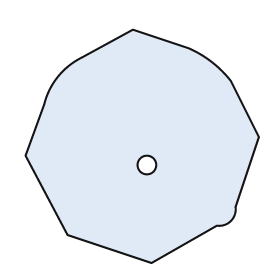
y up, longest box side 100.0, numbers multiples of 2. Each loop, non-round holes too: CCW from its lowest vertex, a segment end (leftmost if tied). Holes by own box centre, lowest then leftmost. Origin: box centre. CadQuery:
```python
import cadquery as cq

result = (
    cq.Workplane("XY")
    .moveTo(4.0, -50.0)
    .lineTo(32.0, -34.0)
    .threePointArc((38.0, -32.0), (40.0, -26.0))
    .lineTo(50.0, 4.0)
    .lineTo(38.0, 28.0)
    .threePointArc((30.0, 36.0), (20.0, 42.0))
    .lineTo(-4.0, 50.0)
    .lineTo(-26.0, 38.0)
    .threePointArc((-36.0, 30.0), (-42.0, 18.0))
    .lineTo(-50.0, -4.0)
    .lineTo(-32.0, -38.0)
    .close()
    .moveTo(2.0, -8.0)
    .circle(4.0)
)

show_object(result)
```